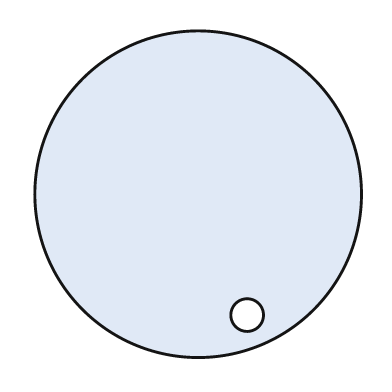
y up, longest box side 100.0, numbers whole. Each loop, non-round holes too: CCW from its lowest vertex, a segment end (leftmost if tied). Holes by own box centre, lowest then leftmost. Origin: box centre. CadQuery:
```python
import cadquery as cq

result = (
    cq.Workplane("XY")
    .moveTo(0.0, 0.0)
    .circle(50.0)
    .moveTo(15.0, -37.0)
    .circle(5.0)
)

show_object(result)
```